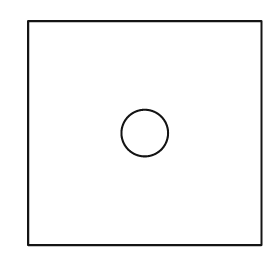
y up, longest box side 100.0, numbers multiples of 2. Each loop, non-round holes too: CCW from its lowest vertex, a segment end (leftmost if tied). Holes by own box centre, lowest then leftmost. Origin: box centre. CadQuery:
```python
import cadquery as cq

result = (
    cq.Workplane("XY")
    .moveTo(-50.0, -48.0)
    .lineTo(50.0, -48.0)
    .lineTo(50.0, 48.0)
    .lineTo(-50.0, 48.0)
    .close()
    .moveTo(0.0, 0.0)
    .circle(10.0)
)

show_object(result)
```